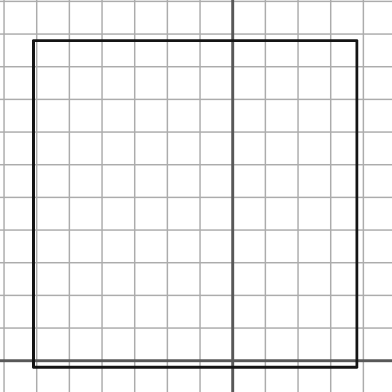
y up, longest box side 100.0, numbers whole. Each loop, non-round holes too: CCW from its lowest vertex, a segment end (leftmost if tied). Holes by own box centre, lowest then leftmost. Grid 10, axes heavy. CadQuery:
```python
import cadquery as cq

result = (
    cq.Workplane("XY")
    .moveTo(-61.0, -2.0)
    .lineTo(38.0, -2.0)
    .lineTo(38.0, 98.0)
    .lineTo(-61.0, 98.0)
    .close()
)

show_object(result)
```